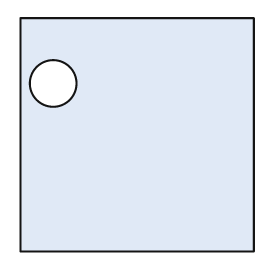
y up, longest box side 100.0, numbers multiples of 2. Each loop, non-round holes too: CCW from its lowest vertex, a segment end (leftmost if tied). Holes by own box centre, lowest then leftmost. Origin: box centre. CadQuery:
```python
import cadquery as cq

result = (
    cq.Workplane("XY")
    .moveTo(-50.0, -50.0)
    .lineTo(50.0, -50.0)
    .lineTo(50.0, 50.0)
    .lineTo(-50.0, 50.0)
    .close()
    .moveTo(-36.0, 22.0)
    .circle(10.0)
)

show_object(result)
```